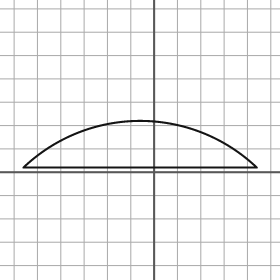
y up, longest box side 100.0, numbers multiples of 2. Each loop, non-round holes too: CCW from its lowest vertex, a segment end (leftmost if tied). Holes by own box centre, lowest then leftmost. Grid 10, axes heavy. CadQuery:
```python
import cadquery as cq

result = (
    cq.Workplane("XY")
    .moveTo(-56.0, 2.0)
    .lineTo(44.0, 2.0)
    .threePointArc((-6.0, 22.0), (-56.0, 2.0))
    .close()
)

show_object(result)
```